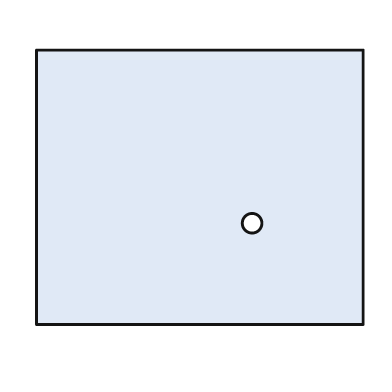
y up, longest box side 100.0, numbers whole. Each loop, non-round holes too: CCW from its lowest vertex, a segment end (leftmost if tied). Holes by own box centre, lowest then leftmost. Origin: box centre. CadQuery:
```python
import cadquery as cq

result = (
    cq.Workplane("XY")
    .moveTo(-50.0, -42.0)
    .lineTo(50.0, -42.0)
    .lineTo(50.0, 42.0)
    .lineTo(-50.0, 42.0)
    .close()
    .moveTo(16.0, -11.0)
    .circle(3.0)
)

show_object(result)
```